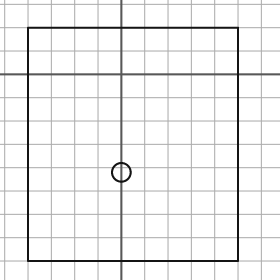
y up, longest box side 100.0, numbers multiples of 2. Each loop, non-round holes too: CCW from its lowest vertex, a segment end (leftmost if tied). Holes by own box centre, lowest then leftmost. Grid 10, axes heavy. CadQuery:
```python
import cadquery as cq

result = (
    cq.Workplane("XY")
    .moveTo(-40.0, -80.0)
    .lineTo(50.0, -80.0)
    .lineTo(50.0, 20.0)
    .lineTo(-40.0, 20.0)
    .close()
    .moveTo(0.0, -42.0)
    .circle(4.0)
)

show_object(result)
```